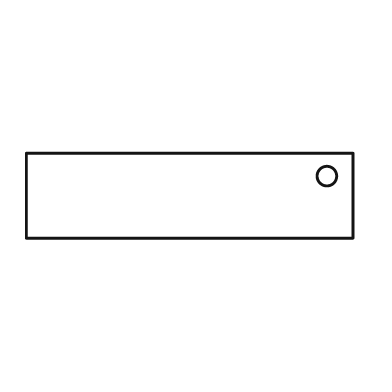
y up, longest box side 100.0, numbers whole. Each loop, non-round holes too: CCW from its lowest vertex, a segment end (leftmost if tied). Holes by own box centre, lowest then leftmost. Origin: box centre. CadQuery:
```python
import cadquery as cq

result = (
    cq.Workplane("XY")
    .moveTo(-50.0, -13.0)
    .lineTo(50.0, -13.0)
    .lineTo(50.0, 13.0)
    .lineTo(-50.0, 13.0)
    .close()
    .moveTo(42.0, 6.0)
    .circle(3.0)
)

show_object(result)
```